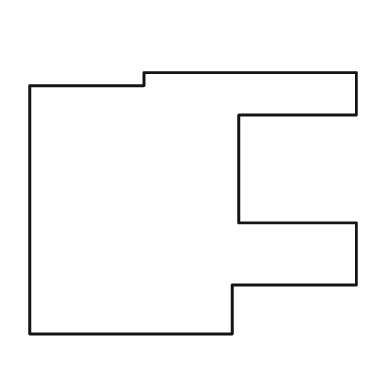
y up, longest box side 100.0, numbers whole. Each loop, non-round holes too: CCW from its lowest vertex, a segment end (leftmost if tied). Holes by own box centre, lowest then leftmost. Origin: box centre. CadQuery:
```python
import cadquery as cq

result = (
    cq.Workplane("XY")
    .moveTo(-50.0, -40.0)
    .lineTo(12.0, -40.0)
    .lineTo(12.0, -25.0)
    .lineTo(50.0, -25.0)
    .lineTo(50.0, -6.0)
    .lineTo(14.0, -6.0)
    .lineTo(14.0, 27.0)
    .lineTo(50.0, 27.0)
    .lineTo(50.0, 40.0)
    .lineTo(-15.0, 40.0)
    .lineTo(-15.0, 36.0)
    .lineTo(-50.0, 36.0)
    .close()
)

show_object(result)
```